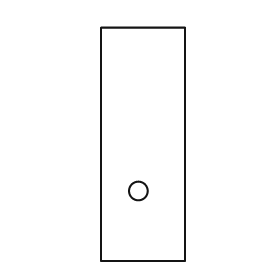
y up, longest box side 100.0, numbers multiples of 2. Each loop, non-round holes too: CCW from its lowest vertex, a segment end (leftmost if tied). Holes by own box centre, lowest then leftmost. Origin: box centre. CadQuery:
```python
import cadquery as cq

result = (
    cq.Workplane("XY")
    .moveTo(-18.0, -50.0)
    .lineTo(18.0, -50.0)
    .lineTo(18.0, 50.0)
    .lineTo(-18.0, 50.0)
    .close()
    .moveTo(-2.0, -20.0)
    .circle(4.0)
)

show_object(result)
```